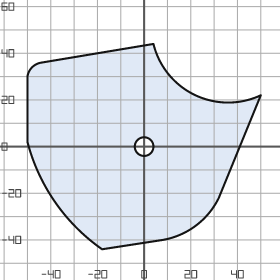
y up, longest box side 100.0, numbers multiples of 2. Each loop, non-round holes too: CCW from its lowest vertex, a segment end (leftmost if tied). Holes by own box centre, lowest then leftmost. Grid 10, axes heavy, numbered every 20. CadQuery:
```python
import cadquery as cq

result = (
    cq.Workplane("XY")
    .moveTo(-18.0, -44.0)
    .lineTo(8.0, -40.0)
    .threePointArc((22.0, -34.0), (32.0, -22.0))
    .lineTo(50.0, 22.0)
    .threePointArc((22.0, 22.0), (4.0, 44.0))
    .lineTo(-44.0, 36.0)
    .threePointArc((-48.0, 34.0), (-50.0, 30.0))
    .lineTo(-50.0, 2.0)
    .threePointArc((-38.0, -24.0), (-18.0, -44.0))
    .close()
    .moveTo(0.0, 0.0)
    .circle(4.0)
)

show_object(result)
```